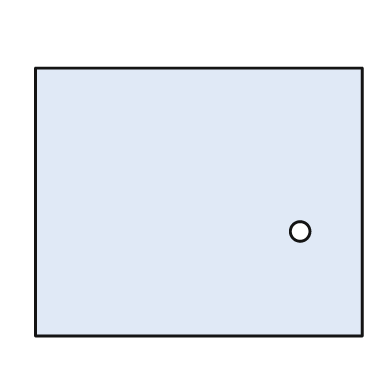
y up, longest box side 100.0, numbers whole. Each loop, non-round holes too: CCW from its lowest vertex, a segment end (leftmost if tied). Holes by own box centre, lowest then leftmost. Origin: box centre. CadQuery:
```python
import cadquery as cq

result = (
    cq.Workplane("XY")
    .moveTo(-50.0, -41.0)
    .lineTo(50.0, -41.0)
    .lineTo(50.0, 41.0)
    .lineTo(-50.0, 41.0)
    .close()
    .moveTo(31.0, -9.0)
    .circle(3.0)
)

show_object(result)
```